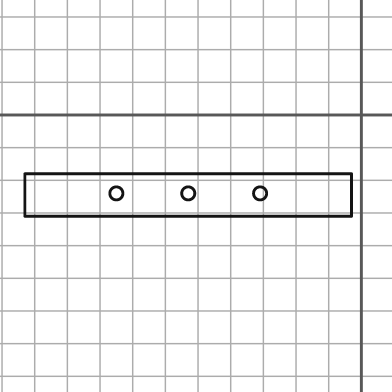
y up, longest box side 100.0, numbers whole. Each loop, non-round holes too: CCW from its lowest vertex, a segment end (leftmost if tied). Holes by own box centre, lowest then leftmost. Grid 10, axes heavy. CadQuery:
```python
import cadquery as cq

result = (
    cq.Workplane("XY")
    .moveTo(-103.0, -31.0)
    .lineTo(-3.0, -31.0)
    .lineTo(-3.0, -18.0)
    .lineTo(-103.0, -18.0)
    .close()
    .moveTo(-75.0, -24.0)
    .circle(2.0)
    .moveTo(-53.0, -24.0)
    .circle(2.0)
    .moveTo(-31.0, -24.0)
    .circle(2.0)
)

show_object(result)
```